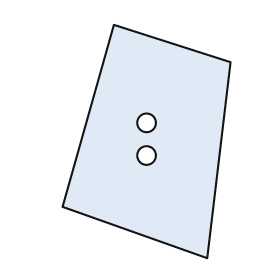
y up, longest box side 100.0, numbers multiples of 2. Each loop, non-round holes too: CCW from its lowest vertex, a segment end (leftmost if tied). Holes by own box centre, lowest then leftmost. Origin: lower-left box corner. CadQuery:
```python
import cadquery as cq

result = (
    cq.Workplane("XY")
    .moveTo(62.0, 0.0)
    .lineTo(72.0, 84.0)
    .lineTo(22.0, 100.0)
    .lineTo(0.0, 22.0)
    .close()
    .moveTo(36.0, 44.0)
    .circle(4.0)
    .moveTo(36.0, 58.0)
    .circle(4.0)
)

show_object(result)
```